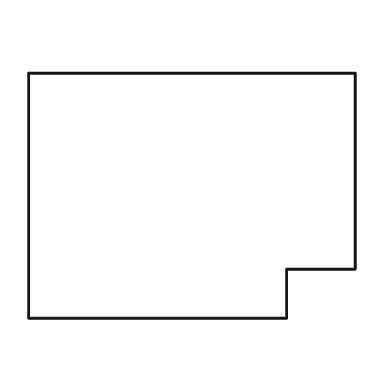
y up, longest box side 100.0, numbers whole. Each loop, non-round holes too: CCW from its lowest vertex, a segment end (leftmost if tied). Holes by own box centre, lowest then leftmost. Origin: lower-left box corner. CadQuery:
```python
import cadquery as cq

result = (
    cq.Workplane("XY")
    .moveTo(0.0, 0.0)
    .lineTo(79.0, 0.0)
    .lineTo(79.0, 15.0)
    .lineTo(100.0, 15.0)
    .lineTo(100.0, 75.0)
    .lineTo(0.0, 75.0)
    .close()
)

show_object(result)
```